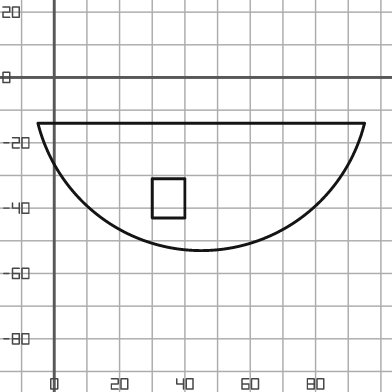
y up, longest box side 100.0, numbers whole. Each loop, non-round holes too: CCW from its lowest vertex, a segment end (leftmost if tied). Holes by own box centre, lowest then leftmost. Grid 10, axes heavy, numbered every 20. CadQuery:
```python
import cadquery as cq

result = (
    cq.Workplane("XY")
    .moveTo(-5.0, -14.0)
    .threePointArc((45.0, -53.0), (95.0, -14.0))
    .close()
    .moveTo(30.0, -43.0)
    .lineTo(40.0, -43.0)
    .lineTo(40.0, -31.0)
    .lineTo(30.0, -31.0)
    .close()
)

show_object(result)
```